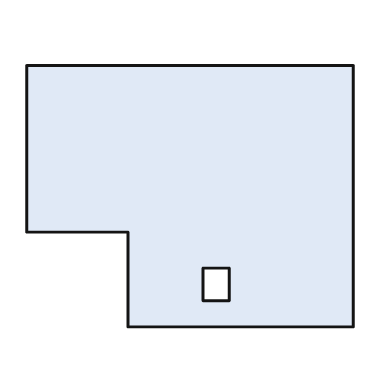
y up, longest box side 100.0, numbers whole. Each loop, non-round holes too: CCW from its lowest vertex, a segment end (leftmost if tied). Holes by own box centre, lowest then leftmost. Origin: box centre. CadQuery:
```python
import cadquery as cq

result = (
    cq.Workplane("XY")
    .moveTo(-19.0, -40.0)
    .lineTo(50.0, -40.0)
    .lineTo(50.0, 40.0)
    .lineTo(-50.0, 40.0)
    .lineTo(-50.0, -11.0)
    .lineTo(-19.0, -11.0)
    .close()
    .moveTo(4.0, -32.0)
    .lineTo(12.0, -32.0)
    .lineTo(12.0, -22.0)
    .lineTo(4.0, -22.0)
    .close()
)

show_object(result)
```